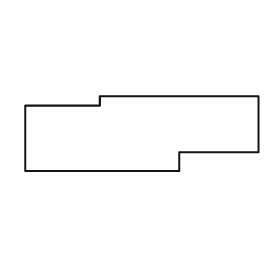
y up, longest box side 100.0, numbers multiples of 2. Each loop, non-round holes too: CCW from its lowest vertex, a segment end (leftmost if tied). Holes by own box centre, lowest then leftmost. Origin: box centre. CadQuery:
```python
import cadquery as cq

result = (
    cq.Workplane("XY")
    .moveTo(-50.0, -16.0)
    .lineTo(16.0, -16.0)
    .lineTo(16.0, -8.0)
    .lineTo(50.0, -8.0)
    .lineTo(50.0, 16.0)
    .lineTo(-18.0, 16.0)
    .lineTo(-18.0, 12.0)
    .lineTo(-50.0, 12.0)
    .close()
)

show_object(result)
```